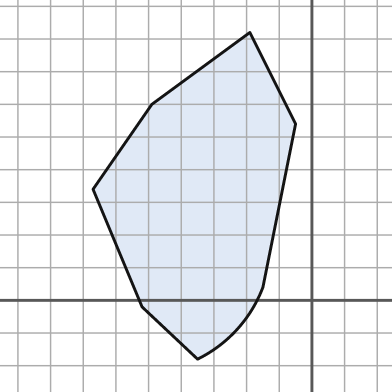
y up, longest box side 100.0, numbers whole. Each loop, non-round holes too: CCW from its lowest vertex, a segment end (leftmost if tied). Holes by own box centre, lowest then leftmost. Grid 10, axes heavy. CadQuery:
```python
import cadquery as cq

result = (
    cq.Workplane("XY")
    .moveTo(-35.0, -18.0)
    .threePointArc((-23.0, -9.0), (-15.0, 4.0))
    .lineTo(-5.0, 54.0)
    .lineTo(-19.0, 82.0)
    .lineTo(-49.0, 60.0)
    .lineTo(-67.0, 34.0)
    .lineTo(-52.0, -2.0)
    .close()
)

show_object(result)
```